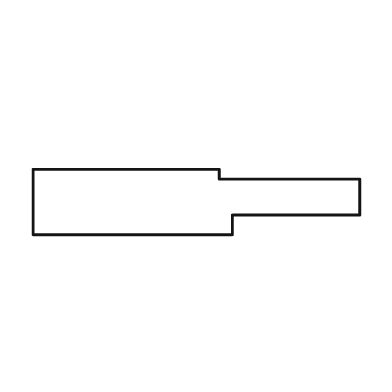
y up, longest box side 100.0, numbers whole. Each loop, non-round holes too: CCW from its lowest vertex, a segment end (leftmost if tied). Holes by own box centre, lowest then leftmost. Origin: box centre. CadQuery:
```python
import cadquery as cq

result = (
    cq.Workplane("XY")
    .moveTo(-50.0, -10.0)
    .lineTo(11.0, -10.0)
    .lineTo(11.0, -4.0)
    .lineTo(50.0, -4.0)
    .lineTo(50.0, 7.0)
    .lineTo(7.0, 7.0)
    .lineTo(7.0, 10.0)
    .lineTo(-50.0, 10.0)
    .close()
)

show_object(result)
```